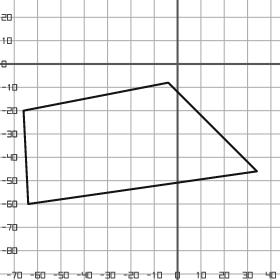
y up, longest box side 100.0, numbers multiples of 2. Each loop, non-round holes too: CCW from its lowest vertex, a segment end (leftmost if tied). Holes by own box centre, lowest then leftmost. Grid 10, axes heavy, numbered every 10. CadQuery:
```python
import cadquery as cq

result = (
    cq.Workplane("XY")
    .moveTo(-64.0, -60.0)
    .lineTo(34.0, -46.0)
    .lineTo(-4.0, -8.0)
    .lineTo(-66.0, -20.0)
    .close()
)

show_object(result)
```